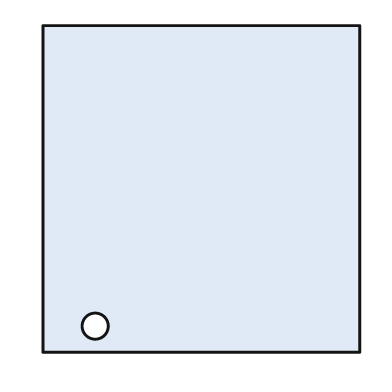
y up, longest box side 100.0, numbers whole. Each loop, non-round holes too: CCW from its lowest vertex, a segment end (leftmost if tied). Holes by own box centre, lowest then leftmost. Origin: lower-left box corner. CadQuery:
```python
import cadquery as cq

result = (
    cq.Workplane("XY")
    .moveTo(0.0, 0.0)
    .lineTo(97.0, 0.0)
    .lineTo(97.0, 100.0)
    .lineTo(0.0, 100.0)
    .close()
    .moveTo(16.0, 8.0)
    .circle(4.0)
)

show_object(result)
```